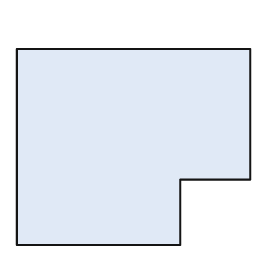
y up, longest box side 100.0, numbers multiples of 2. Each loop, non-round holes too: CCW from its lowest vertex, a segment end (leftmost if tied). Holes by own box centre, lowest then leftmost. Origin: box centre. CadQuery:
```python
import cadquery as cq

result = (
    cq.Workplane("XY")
    .moveTo(-50.0, -42.0)
    .lineTo(20.0, -42.0)
    .lineTo(20.0, -14.0)
    .lineTo(50.0, -14.0)
    .lineTo(50.0, 42.0)
    .lineTo(-50.0, 42.0)
    .close()
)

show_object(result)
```